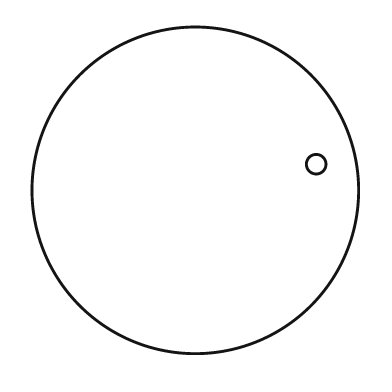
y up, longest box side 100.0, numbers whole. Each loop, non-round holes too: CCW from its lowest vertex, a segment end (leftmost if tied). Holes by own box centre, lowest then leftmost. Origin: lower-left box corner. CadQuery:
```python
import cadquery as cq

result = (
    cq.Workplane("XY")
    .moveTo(50.0, 50.0)
    .circle(50.0)
    .moveTo(87.0, 58.0)
    .circle(3.0)
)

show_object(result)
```